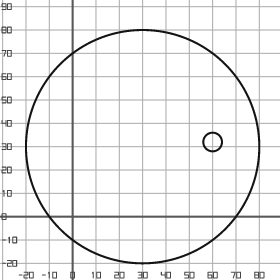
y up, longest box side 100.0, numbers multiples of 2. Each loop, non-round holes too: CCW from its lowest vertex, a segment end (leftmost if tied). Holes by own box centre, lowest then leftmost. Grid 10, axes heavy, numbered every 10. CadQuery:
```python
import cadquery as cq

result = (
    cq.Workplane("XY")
    .moveTo(30.0, 30.0)
    .circle(50.0)
    .moveTo(60.0, 32.0)
    .circle(4.0)
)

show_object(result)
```